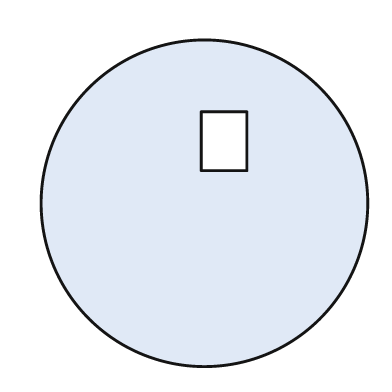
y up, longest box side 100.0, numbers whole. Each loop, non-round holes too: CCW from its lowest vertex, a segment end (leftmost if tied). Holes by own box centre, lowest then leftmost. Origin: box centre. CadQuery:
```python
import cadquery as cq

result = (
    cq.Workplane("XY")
    .moveTo(0.0, 0.0)
    .circle(50.0)
    .moveTo(-1.0, 10.0)
    .lineTo(13.0, 10.0)
    .lineTo(13.0, 28.0)
    .lineTo(-1.0, 28.0)
    .close()
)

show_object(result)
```